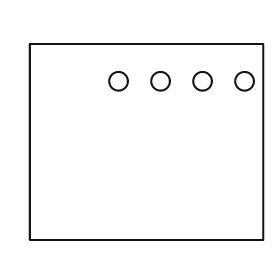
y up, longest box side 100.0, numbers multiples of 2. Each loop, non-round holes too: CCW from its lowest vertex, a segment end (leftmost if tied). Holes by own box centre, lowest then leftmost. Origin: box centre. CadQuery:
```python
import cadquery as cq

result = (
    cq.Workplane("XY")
    .moveTo(-50.0, -42.0)
    .lineTo(50.0, -42.0)
    .lineTo(50.0, 42.0)
    .lineTo(-50.0, 42.0)
    .close()
    .moveTo(-12.0, 26.0)
    .circle(4.0)
    .moveTo(6.0, 26.0)
    .circle(4.0)
    .moveTo(24.0, 26.0)
    .circle(4.0)
    .moveTo(42.0, 26.0)
    .circle(4.0)
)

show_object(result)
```